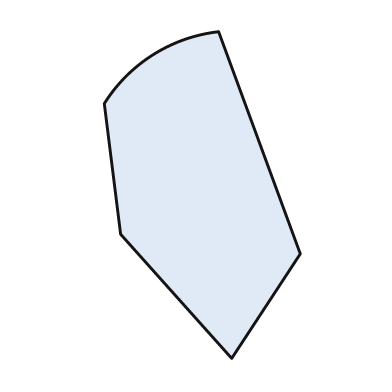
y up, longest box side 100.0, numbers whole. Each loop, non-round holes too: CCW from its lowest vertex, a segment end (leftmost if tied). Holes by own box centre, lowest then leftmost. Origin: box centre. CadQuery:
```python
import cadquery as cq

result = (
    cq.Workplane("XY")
    .moveTo(9.0, -50.0)
    .lineTo(30.0, -18.0)
    .lineTo(5.0, 50.0)
    .threePointArc((-15.0, 43.0), (-30.0, 28.0))
    .lineTo(-25.0, -12.0)
    .close()
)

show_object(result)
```